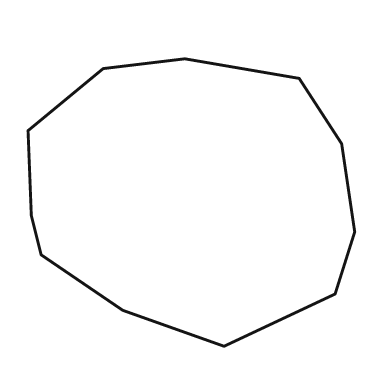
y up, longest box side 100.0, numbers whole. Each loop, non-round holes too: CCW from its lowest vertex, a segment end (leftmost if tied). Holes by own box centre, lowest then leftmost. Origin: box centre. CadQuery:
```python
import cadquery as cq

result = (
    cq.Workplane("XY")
    .moveTo(10.0, -44.0)
    .lineTo(44.0, -28.0)
    .lineTo(50.0, -9.0)
    .lineTo(46.0, 18.0)
    .lineTo(33.0, 38.0)
    .lineTo(-2.0, 44.0)
    .lineTo(-27.0, 41.0)
    .lineTo(-50.0, 22.0)
    .lineTo(-49.0, -4.0)
    .lineTo(-46.0, -16.0)
    .lineTo(-21.0, -33.0)
    .close()
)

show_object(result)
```